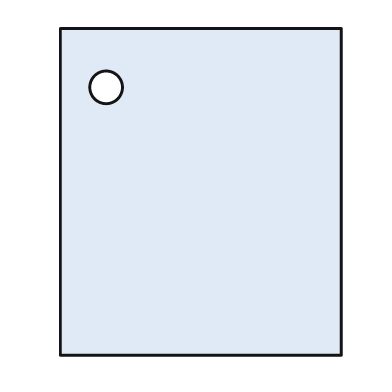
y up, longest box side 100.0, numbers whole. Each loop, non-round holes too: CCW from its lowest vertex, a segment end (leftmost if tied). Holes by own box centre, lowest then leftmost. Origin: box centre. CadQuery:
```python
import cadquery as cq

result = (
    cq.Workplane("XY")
    .moveTo(-43.0, -50.0)
    .lineTo(43.0, -50.0)
    .lineTo(43.0, 50.0)
    .lineTo(-43.0, 50.0)
    .close()
    .moveTo(-29.0, 32.0)
    .circle(5.0)
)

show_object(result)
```